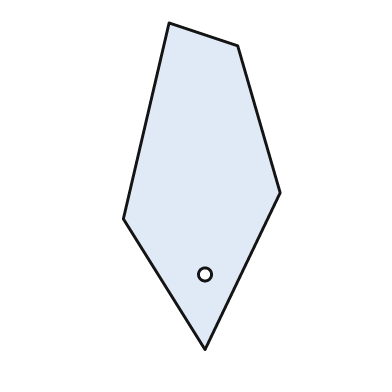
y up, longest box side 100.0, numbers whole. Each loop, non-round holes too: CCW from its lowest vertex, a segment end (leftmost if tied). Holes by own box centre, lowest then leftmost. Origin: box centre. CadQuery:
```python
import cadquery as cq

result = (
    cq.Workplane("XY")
    .moveTo(1.0, -50.0)
    .lineTo(24.0, -2.0)
    .lineTo(11.0, 43.0)
    .lineTo(-10.0, 50.0)
    .lineTo(-24.0, -10.0)
    .close()
    .moveTo(1.0, -27.0)
    .circle(2.0)
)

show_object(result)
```